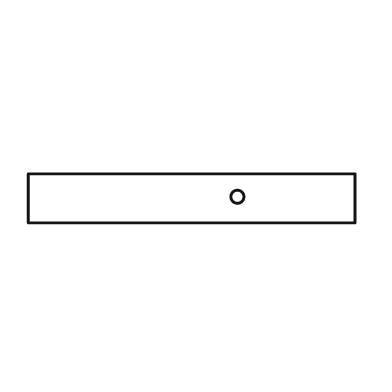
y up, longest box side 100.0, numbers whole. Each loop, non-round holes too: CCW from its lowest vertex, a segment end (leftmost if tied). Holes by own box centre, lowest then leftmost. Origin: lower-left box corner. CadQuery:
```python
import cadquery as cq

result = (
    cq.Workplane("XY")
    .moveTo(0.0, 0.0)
    .lineTo(100.0, 0.0)
    .lineTo(100.0, 15.0)
    .lineTo(0.0, 15.0)
    .close()
    .moveTo(64.0, 8.0)
    .circle(2.0)
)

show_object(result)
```